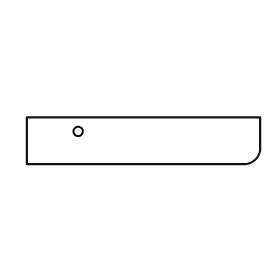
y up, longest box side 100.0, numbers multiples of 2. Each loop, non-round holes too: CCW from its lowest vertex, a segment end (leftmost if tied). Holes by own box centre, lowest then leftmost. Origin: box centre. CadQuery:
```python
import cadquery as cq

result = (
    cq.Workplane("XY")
    .moveTo(-50.0, -10.0)
    .lineTo(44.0, -10.0)
    .threePointArc((48.0, -8.0), (50.0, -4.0))
    .lineTo(50.0, 10.0)
    .lineTo(-50.0, 10.0)
    .close()
    .moveTo(-28.0, 4.0)
    .circle(2.0)
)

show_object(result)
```